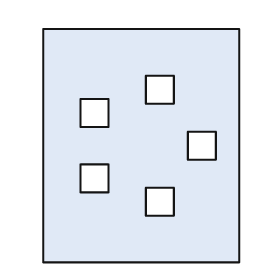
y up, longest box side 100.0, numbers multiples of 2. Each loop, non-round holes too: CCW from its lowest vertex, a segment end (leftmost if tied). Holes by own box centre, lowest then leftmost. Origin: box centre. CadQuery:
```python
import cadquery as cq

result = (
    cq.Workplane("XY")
    .moveTo(-42.0, -50.0)
    .lineTo(42.0, -50.0)
    .lineTo(42.0, 50.0)
    .lineTo(-42.0, 50.0)
    .close()
    .moveTo(2.0, -30.0)
    .lineTo(14.0, -30.0)
    .lineTo(14.0, -18.0)
    .lineTo(2.0, -18.0)
    .close()
    .moveTo(-26.0, -20.0)
    .lineTo(-14.0, -20.0)
    .lineTo(-14.0, -8.0)
    .lineTo(-26.0, -8.0)
    .close()
    .moveTo(20.0, -6.0)
    .lineTo(32.0, -6.0)
    .lineTo(32.0, 6.0)
    .lineTo(20.0, 6.0)
    .close()
    .moveTo(-26.0, 8.0)
    .lineTo(-14.0, 8.0)
    .lineTo(-14.0, 20.0)
    .lineTo(-26.0, 20.0)
    .close()
    .moveTo(2.0, 18.0)
    .lineTo(14.0, 18.0)
    .lineTo(14.0, 30.0)
    .lineTo(2.0, 30.0)
    .close()
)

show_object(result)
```